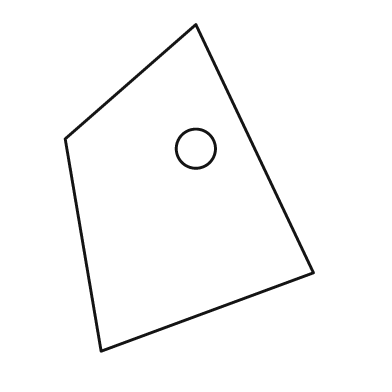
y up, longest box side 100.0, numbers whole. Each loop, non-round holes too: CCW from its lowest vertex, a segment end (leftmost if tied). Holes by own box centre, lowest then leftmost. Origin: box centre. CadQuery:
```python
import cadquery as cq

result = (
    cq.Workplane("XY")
    .moveTo(-27.0, -50.0)
    .lineTo(38.0, -26.0)
    .lineTo(2.0, 50.0)
    .lineTo(-38.0, 15.0)
    .close()
    .moveTo(2.0, 12.0)
    .circle(6.0)
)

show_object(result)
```